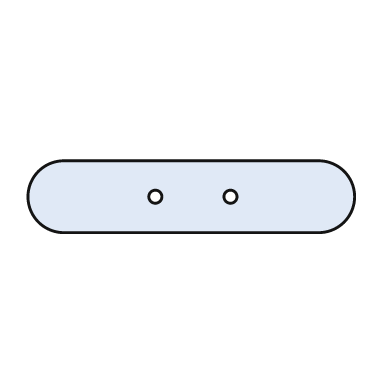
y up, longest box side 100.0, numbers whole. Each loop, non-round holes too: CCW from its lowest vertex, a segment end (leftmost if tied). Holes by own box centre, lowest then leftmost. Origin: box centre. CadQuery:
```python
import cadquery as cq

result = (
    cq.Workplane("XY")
    .moveTo(-39.0, -11.0)
    .lineTo(39.0, -11.0)
    .threePointArc((50.0, 0.0), (39.0, 11.0))
    .lineTo(-39.0, 11.0)
    .threePointArc((-50.0, 0.0), (-39.0, -11.0))
    .close()
    .moveTo(-11.0, 0.0)
    .circle(2.0)
    .moveTo(12.0, 0.0)
    .circle(2.0)
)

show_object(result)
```